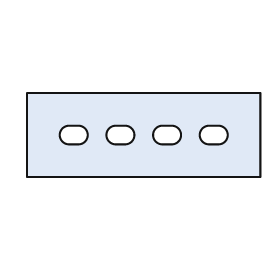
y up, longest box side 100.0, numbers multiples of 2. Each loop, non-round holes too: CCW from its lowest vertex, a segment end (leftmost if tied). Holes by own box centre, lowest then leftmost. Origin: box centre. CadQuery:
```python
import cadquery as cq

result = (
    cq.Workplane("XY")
    .moveTo(-50.0, -18.0)
    .lineTo(50.0, -18.0)
    .lineTo(50.0, 18.0)
    .lineTo(-50.0, 18.0)
    .close()
    .moveTo(-32.0, -4.0)
    .lineTo(-28.0, -4.0)
    .threePointArc((-24.0, 0.0), (-28.0, 4.0))
    .lineTo(-32.0, 4.0)
    .threePointArc((-36.0, 0.0), (-32.0, -4.0))
    .close()
    .moveTo(-12.0, -4.0)
    .lineTo(-8.0, -4.0)
    .threePointArc((-4.0, 0.0), (-8.0, 4.0))
    .lineTo(-12.0, 4.0)
    .threePointArc((-16.0, 0.0), (-12.0, -4.0))
    .close()
    .moveTo(8.0, -4.0)
    .lineTo(12.0, -4.0)
    .threePointArc((16.0, 0.0), (12.0, 4.0))
    .lineTo(8.0, 4.0)
    .threePointArc((4.0, 0.0), (8.0, -4.0))
    .close()
    .moveTo(28.0, -4.0)
    .lineTo(32.0, -4.0)
    .threePointArc((36.0, 0.0), (32.0, 4.0))
    .lineTo(28.0, 4.0)
    .threePointArc((24.0, 0.0), (28.0, -4.0))
    .close()
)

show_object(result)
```